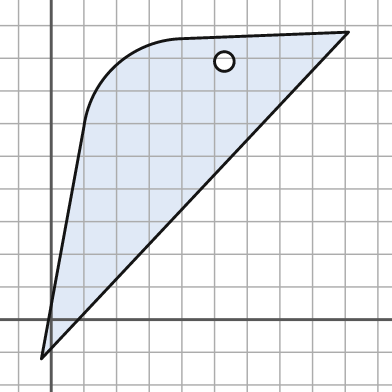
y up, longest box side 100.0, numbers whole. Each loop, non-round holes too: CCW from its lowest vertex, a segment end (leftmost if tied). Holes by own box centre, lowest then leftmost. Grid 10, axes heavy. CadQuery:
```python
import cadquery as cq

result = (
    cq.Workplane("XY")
    .moveTo(-3.0, -12.0)
    .lineTo(91.0, 88.0)
    .lineTo(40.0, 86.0)
    .threePointArc((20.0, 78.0), (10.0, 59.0))
    .close()
    .moveTo(53.0, 79.0)
    .circle(3.0)
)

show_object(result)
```